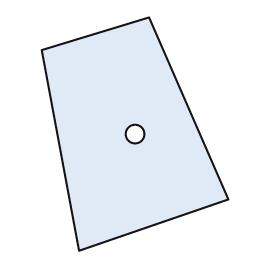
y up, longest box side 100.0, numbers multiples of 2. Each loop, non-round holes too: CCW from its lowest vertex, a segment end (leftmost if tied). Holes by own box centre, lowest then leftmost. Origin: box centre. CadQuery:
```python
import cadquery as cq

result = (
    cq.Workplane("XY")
    .moveTo(-24.0, -50.0)
    .lineTo(40.0, -28.0)
    .lineTo(6.0, 50.0)
    .lineTo(-40.0, 36.0)
    .close()
    .moveTo(0.0, 0.0)
    .circle(4.0)
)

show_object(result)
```